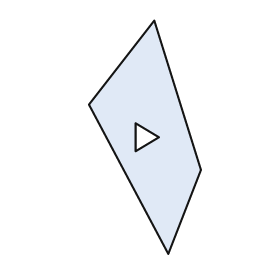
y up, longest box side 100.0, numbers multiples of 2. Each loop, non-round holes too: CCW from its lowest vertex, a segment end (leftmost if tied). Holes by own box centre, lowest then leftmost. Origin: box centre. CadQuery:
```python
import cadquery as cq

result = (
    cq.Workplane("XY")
    .moveTo(10.0, -50.0)
    .lineTo(24.0, -14.0)
    .lineTo(4.0, 50.0)
    .lineTo(-24.0, 14.0)
    .close()
    .moveTo(-4.0, -6.0)
    .lineTo(6.0, 0.0)
    .lineTo(-4.0, 6.0)
    .close()
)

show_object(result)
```